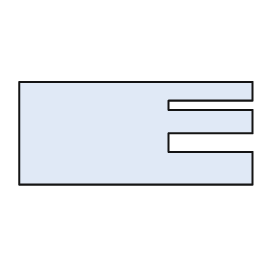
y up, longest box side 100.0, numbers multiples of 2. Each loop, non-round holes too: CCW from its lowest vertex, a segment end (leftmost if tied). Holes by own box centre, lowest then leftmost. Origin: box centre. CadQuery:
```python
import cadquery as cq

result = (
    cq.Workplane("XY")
    .moveTo(-50.0, -22.0)
    .lineTo(50.0, -22.0)
    .lineTo(50.0, -8.0)
    .lineTo(14.0, -8.0)
    .lineTo(14.0, 0.0)
    .lineTo(50.0, 0.0)
    .lineTo(50.0, 10.0)
    .lineTo(14.0, 10.0)
    .lineTo(14.0, 14.0)
    .lineTo(50.0, 14.0)
    .lineTo(50.0, 22.0)
    .lineTo(-50.0, 22.0)
    .close()
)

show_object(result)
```